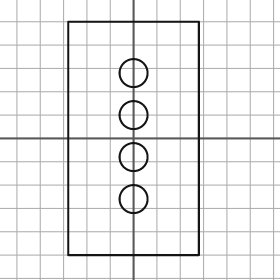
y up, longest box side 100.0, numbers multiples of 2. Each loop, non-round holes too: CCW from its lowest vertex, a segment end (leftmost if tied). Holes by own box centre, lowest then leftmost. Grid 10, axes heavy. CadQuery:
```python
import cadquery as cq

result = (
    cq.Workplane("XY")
    .moveTo(-28.0, -50.0)
    .lineTo(28.0, -50.0)
    .lineTo(28.0, 50.0)
    .lineTo(-28.0, 50.0)
    .close()
    .moveTo(0.0, -26.0)
    .circle(6.0)
    .moveTo(0.0, -8.0)
    .circle(6.0)
    .moveTo(0.0, 10.0)
    .circle(6.0)
    .moveTo(0.0, 28.0)
    .circle(6.0)
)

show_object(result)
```